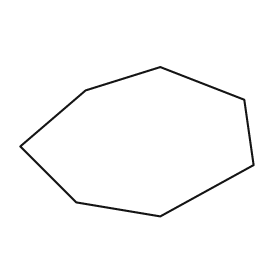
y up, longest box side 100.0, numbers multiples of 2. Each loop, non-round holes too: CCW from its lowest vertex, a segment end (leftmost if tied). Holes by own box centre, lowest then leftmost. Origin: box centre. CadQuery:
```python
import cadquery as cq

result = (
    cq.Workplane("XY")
    .moveTo(10.0, -32.0)
    .lineTo(50.0, -10.0)
    .lineTo(46.0, 18.0)
    .lineTo(10.0, 32.0)
    .lineTo(-22.0, 22.0)
    .lineTo(-50.0, -2.0)
    .lineTo(-26.0, -26.0)
    .close()
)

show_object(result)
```